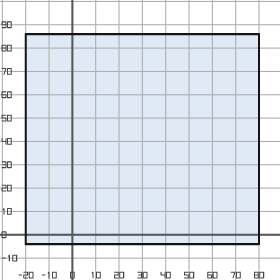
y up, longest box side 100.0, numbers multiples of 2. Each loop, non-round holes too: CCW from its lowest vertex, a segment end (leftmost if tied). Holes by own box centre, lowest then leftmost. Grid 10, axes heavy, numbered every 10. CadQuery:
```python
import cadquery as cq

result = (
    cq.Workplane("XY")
    .moveTo(-20.0, -4.0)
    .lineTo(80.0, -4.0)
    .lineTo(80.0, 86.0)
    .lineTo(-20.0, 86.0)
    .close()
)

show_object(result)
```